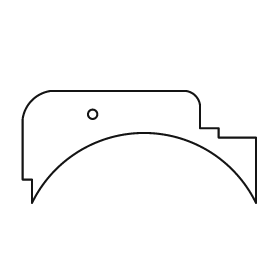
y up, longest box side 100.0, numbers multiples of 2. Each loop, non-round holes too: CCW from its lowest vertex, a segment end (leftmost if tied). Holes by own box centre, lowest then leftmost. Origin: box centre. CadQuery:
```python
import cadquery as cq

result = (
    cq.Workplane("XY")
    .moveTo(-46.0, -24.0)
    .threePointArc((2.0, 6.0), (50.0, -24.0))
    .lineTo(50.0, 4.0)
    .lineTo(34.0, 4.0)
    .lineTo(34.0, 8.0)
    .lineTo(26.0, 8.0)
    .lineTo(26.0, 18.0)
    .threePointArc((24.0, 22.0), (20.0, 24.0))
    .lineTo(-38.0, 24.0)
    .threePointArc((-46.0, 20.0), (-50.0, 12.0))
    .lineTo(-50.0, -14.0)
    .lineTo(-46.0, -14.0)
    .close()
    .moveTo(-20.0, 14.0)
    .circle(2.0)
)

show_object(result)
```